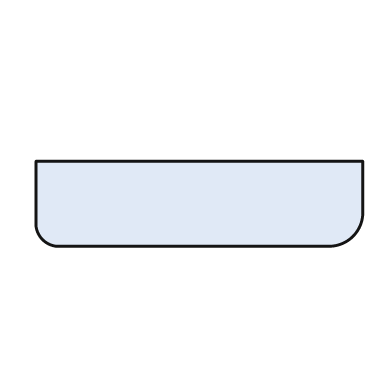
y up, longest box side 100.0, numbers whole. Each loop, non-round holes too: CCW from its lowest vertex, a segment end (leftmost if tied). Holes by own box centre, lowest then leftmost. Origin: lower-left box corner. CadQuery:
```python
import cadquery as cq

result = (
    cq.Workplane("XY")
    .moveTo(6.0, 0.0)
    .lineTo(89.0, 0.0)
    .threePointArc((97.0, 3.0), (100.0, 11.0))
    .lineTo(100.0, 26.0)
    .lineTo(0.0, 26.0)
    .lineTo(0.0, 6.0)
    .threePointArc((2.0, 2.0), (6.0, 0.0))
    .close()
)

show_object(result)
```